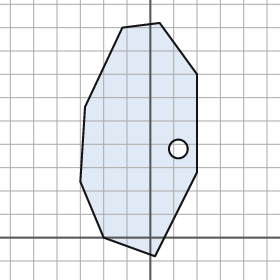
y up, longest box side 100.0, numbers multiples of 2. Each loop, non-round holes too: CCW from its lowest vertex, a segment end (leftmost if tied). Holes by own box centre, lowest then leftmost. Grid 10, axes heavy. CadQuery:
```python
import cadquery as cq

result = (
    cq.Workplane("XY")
    .moveTo(2.0, -8.0)
    .lineTo(20.0, 28.0)
    .lineTo(20.0, 70.0)
    .lineTo(4.0, 92.0)
    .lineTo(-12.0, 90.0)
    .lineTo(-28.0, 56.0)
    .lineTo(-30.0, 24.0)
    .lineTo(-20.0, 0.0)
    .close()
    .moveTo(12.0, 38.0)
    .circle(4.0)
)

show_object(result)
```